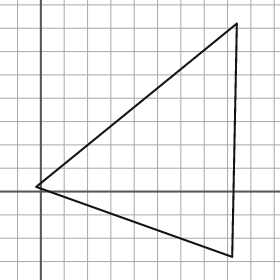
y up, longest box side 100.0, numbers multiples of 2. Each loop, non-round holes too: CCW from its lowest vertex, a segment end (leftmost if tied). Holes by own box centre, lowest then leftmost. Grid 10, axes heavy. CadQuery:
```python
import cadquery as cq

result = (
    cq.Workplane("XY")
    .moveTo(82.0, -28.0)
    .lineTo(84.0, 72.0)
    .lineTo(-2.0, 2.0)
    .close()
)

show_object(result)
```